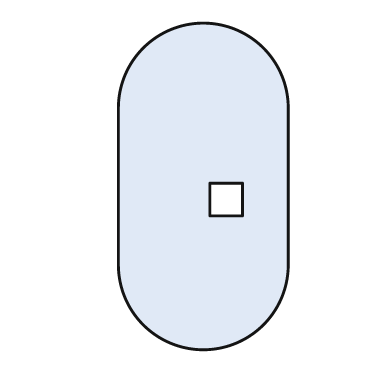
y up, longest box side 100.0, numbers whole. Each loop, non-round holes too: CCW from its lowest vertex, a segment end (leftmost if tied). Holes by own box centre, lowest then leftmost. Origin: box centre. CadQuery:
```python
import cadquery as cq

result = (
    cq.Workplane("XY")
    .moveTo(-26.0, -24.0)
    .threePointArc((0.0, -50.0), (26.0, -24.0))
    .lineTo(26.0, 24.0)
    .threePointArc((0.0, 50.0), (-26.0, 24.0))
    .close()
    .moveTo(2.0, -9.0)
    .lineTo(12.0, -9.0)
    .lineTo(12.0, 1.0)
    .lineTo(2.0, 1.0)
    .close()
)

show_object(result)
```